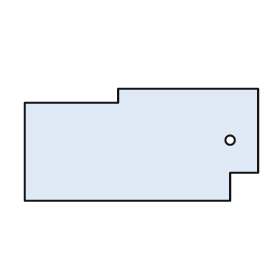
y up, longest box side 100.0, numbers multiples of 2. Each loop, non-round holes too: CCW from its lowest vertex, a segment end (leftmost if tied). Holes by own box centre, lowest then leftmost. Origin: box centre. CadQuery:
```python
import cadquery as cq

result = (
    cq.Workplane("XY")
    .moveTo(-50.0, -24.0)
    .lineTo(38.0, -24.0)
    .lineTo(38.0, -12.0)
    .lineTo(50.0, -12.0)
    .lineTo(50.0, 24.0)
    .lineTo(-10.0, 24.0)
    .lineTo(-10.0, 18.0)
    .lineTo(-50.0, 18.0)
    .close()
    .moveTo(38.0, 2.0)
    .circle(2.0)
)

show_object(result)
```